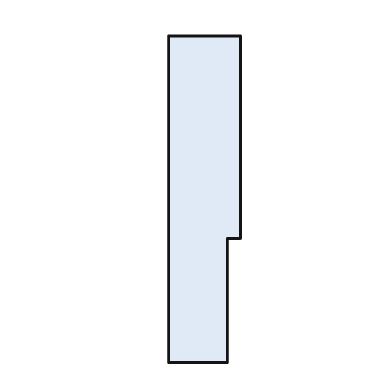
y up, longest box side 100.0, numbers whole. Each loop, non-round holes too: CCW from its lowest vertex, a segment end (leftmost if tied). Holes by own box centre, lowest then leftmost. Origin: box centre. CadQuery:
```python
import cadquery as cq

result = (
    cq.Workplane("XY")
    .moveTo(-11.0, -50.0)
    .lineTo(7.0, -50.0)
    .lineTo(7.0, -12.0)
    .lineTo(11.0, -12.0)
    .lineTo(11.0, 50.0)
    .lineTo(-11.0, 50.0)
    .close()
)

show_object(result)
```